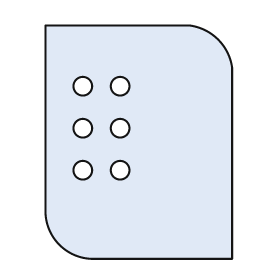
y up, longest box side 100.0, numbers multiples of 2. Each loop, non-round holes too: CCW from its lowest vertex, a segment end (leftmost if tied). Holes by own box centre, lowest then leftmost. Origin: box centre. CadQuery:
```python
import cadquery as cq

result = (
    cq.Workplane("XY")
    .moveTo(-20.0, -50.0)
    .lineTo(40.0, -50.0)
    .lineTo(40.0, 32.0)
    .threePointArc((34.0, 44.0), (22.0, 50.0))
    .lineTo(-40.0, 50.0)
    .lineTo(-40.0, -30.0)
    .threePointArc((-34.0, -44.0), (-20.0, -50.0))
    .close()
    .moveTo(-24.0, -12.0)
    .circle(4.0)
    .moveTo(-8.0, -12.0)
    .circle(4.0)
    .moveTo(-24.0, 6.0)
    .circle(4.0)
    .moveTo(-8.0, 6.0)
    .circle(4.0)
    .moveTo(-24.0, 24.0)
    .circle(4.0)
    .moveTo(-8.0, 24.0)
    .circle(4.0)
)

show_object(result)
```